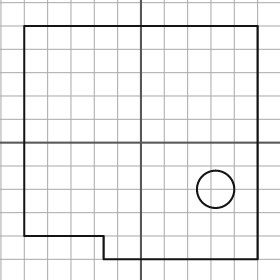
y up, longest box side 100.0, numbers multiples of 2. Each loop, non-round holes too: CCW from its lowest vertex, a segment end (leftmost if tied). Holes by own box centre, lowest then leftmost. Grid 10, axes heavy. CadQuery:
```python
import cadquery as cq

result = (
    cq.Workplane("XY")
    .moveTo(-16.0, -50.0)
    .lineTo(50.0, -50.0)
    .lineTo(50.0, 50.0)
    .lineTo(-50.0, 50.0)
    .lineTo(-50.0, -40.0)
    .lineTo(-16.0, -40.0)
    .close()
    .moveTo(32.0, -20.0)
    .circle(8.0)
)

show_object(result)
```